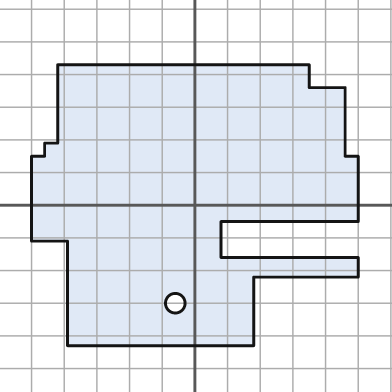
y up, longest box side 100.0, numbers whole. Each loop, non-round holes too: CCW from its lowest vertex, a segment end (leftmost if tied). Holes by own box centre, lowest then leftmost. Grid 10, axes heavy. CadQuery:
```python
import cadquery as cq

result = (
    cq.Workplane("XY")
    .moveTo(-39.0, -43.0)
    .lineTo(18.0, -43.0)
    .lineTo(18.0, -22.0)
    .lineTo(50.0, -22.0)
    .lineTo(50.0, -16.0)
    .lineTo(8.0, -16.0)
    .lineTo(8.0, -5.0)
    .lineTo(50.0, -5.0)
    .lineTo(50.0, 15.0)
    .lineTo(46.0, 15.0)
    .lineTo(46.0, 36.0)
    .lineTo(35.0, 36.0)
    .lineTo(35.0, 43.0)
    .lineTo(-42.0, 43.0)
    .lineTo(-42.0, 19.0)
    .lineTo(-46.0, 19.0)
    .lineTo(-46.0, 15.0)
    .lineTo(-50.0, 15.0)
    .lineTo(-50.0, -11.0)
    .lineTo(-39.0, -11.0)
    .close()
    .moveTo(-6.0, -30.0)
    .circle(3.0)
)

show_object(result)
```